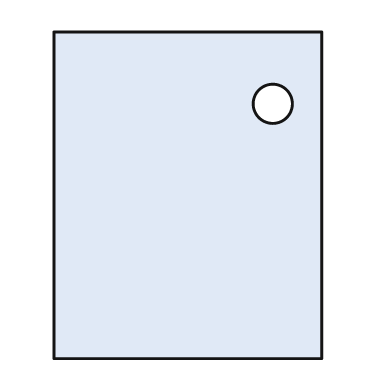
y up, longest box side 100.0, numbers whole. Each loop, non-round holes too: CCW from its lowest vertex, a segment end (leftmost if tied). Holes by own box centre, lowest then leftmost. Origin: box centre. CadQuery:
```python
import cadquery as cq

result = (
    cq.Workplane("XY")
    .moveTo(-41.0, -50.0)
    .lineTo(41.0, -50.0)
    .lineTo(41.0, 50.0)
    .lineTo(-41.0, 50.0)
    .close()
    .moveTo(26.0, 28.0)
    .circle(6.0)
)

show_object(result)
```